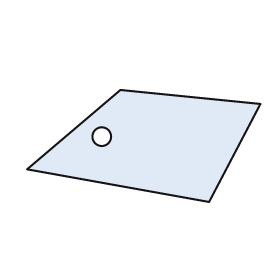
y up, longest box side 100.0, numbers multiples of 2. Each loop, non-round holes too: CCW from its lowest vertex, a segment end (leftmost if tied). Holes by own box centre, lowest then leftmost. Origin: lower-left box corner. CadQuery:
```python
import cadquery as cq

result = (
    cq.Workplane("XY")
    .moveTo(78.0, 0.0)
    .lineTo(100.0, 42.0)
    .lineTo(40.0, 48.0)
    .lineTo(0.0, 14.0)
    .close()
    .moveTo(32.0, 28.0)
    .circle(4.0)
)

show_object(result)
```